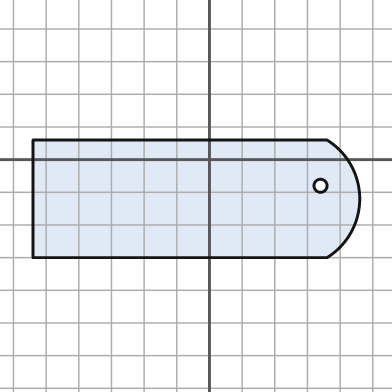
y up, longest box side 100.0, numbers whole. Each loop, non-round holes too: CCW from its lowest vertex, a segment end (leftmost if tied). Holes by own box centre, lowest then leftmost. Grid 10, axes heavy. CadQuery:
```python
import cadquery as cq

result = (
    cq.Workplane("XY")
    .moveTo(-54.0, -30.0)
    .lineTo(36.0, -30.0)
    .threePointArc((46.0, -12.0), (36.0, 6.0))
    .lineTo(-54.0, 6.0)
    .close()
    .moveTo(34.0, -8.0)
    .circle(2.0)
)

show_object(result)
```